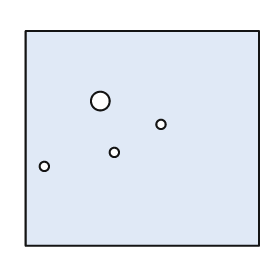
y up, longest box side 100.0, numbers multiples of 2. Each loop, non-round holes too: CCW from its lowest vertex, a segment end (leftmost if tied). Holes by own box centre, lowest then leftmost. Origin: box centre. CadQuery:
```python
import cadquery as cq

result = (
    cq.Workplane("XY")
    .moveTo(-50.0, -46.0)
    .lineTo(50.0, -46.0)
    .lineTo(50.0, 46.0)
    .lineTo(-50.0, 46.0)
    .close()
    .moveTo(-42.0, -12.0)
    .circle(2.0)
    .moveTo(-12.0, -6.0)
    .circle(2.0)
    .moveTo(8.0, 6.0)
    .circle(2.0)
    .moveTo(-18.0, 16.0)
    .circle(4.0)
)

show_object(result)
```